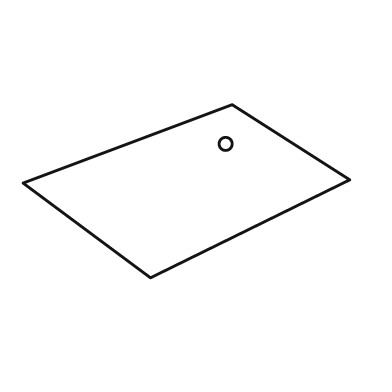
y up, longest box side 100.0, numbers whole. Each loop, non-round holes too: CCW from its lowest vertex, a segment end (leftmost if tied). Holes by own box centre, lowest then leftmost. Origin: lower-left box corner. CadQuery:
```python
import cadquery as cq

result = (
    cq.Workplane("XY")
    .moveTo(39.0, 0.0)
    .lineTo(100.0, 30.0)
    .lineTo(64.0, 53.0)
    .lineTo(0.0, 29.0)
    .close()
    .moveTo(62.0, 41.0)
    .circle(2.0)
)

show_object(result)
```